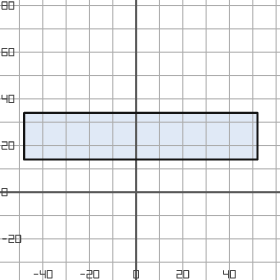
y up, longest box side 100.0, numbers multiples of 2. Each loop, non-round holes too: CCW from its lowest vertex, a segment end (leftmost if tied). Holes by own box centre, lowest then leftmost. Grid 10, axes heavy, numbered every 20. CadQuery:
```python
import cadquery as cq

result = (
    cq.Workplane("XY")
    .moveTo(-48.0, 14.0)
    .lineTo(52.0, 14.0)
    .lineTo(52.0, 34.0)
    .lineTo(-48.0, 34.0)
    .close()
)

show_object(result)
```